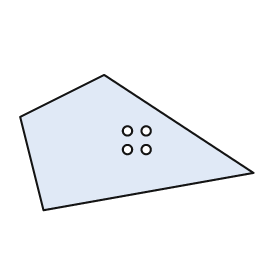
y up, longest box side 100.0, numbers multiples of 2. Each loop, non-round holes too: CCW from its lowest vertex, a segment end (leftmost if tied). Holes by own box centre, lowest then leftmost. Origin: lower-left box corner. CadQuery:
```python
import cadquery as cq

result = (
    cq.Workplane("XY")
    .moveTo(10.0, 0.0)
    .lineTo(100.0, 16.0)
    .lineTo(36.0, 58.0)
    .lineTo(0.0, 40.0)
    .close()
    .moveTo(46.0, 26.0)
    .circle(2.0)
    .moveTo(54.0, 26.0)
    .circle(2.0)
    .moveTo(46.0, 34.0)
    .circle(2.0)
    .moveTo(54.0, 34.0)
    .circle(2.0)
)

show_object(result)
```